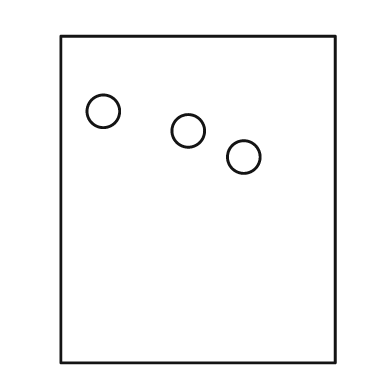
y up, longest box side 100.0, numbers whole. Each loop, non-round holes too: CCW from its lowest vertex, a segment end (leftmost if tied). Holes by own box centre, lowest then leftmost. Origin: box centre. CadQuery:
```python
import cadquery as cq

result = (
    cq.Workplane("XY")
    .moveTo(-42.0, -50.0)
    .lineTo(42.0, -50.0)
    .lineTo(42.0, 50.0)
    .lineTo(-42.0, 50.0)
    .close()
    .moveTo(14.0, 13.0)
    .circle(5.0)
    .moveTo(-3.0, 21.0)
    .circle(5.0)
    .moveTo(-29.0, 27.0)
    .circle(5.0)
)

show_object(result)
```